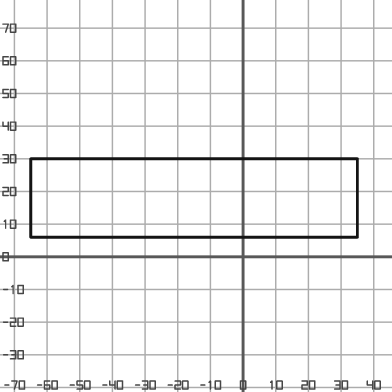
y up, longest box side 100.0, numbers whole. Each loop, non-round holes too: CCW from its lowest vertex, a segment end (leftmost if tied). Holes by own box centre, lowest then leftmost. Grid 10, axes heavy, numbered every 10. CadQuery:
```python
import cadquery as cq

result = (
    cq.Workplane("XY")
    .moveTo(-65.0, 6.0)
    .lineTo(35.0, 6.0)
    .lineTo(35.0, 30.0)
    .lineTo(-65.0, 30.0)
    .close()
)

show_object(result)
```